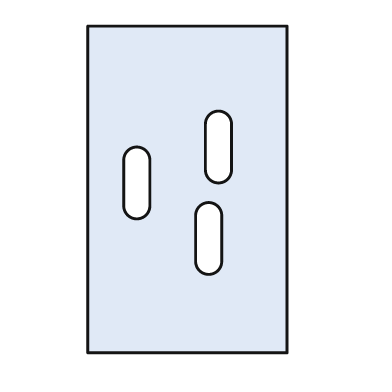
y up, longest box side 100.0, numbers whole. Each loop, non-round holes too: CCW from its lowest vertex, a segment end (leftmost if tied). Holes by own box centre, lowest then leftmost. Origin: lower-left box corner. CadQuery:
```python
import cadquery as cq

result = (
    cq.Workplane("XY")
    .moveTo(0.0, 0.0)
    .lineTo(61.0, 0.0)
    .lineTo(61.0, 100.0)
    .lineTo(0.0, 100.0)
    .close()
    .moveTo(33.0, 28.0)
    .threePointArc((37.0, 24.0), (41.0, 28.0))
    .lineTo(41.0, 42.0)
    .threePointArc((37.0, 46.0), (33.0, 42.0))
    .close()
    .moveTo(11.0, 45.0)
    .threePointArc((15.0, 41.0), (19.0, 45.0))
    .lineTo(19.0, 59.0)
    .threePointArc((15.0, 63.0), (11.0, 59.0))
    .close()
    .moveTo(36.0, 56.0)
    .threePointArc((40.0, 52.0), (44.0, 56.0))
    .lineTo(44.0, 70.0)
    .threePointArc((40.0, 74.0), (36.0, 70.0))
    .close()
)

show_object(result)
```